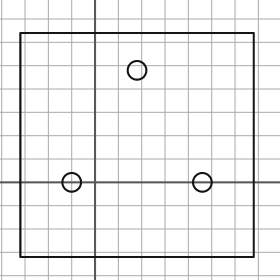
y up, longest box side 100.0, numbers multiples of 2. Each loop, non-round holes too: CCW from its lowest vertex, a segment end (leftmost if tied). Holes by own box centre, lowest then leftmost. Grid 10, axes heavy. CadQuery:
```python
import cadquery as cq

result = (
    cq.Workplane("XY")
    .moveTo(-32.0, -32.0)
    .lineTo(68.0, -32.0)
    .lineTo(68.0, 64.0)
    .lineTo(-32.0, 64.0)
    .close()
    .moveTo(-10.0, 0.0)
    .circle(4.0)
    .moveTo(46.0, 0.0)
    .circle(4.0)
    .moveTo(18.0, 48.0)
    .circle(4.0)
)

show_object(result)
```